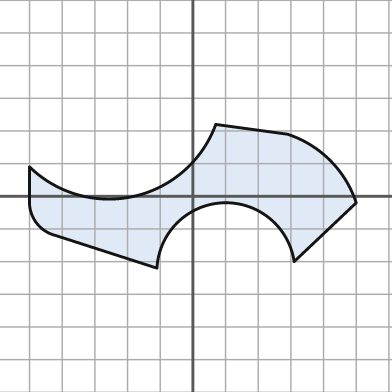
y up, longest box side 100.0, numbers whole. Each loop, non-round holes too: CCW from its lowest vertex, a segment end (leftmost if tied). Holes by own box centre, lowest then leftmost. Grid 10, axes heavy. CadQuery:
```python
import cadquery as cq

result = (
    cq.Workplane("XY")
    .moveTo(-11.0, -22.0)
    .threePointArc((9.0, -2.0), (31.0, -20.0))
    .lineTo(50.0, -2.0)
    .threePointArc((42.0, 11.0), (29.0, 19.0))
    .lineTo(7.0, 22.0)
    .threePointArc((-18.0, 0.0), (-50.0, 9.0))
    .lineTo(-50.0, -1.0)
    .threePointArc((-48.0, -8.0), (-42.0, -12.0))
    .close()
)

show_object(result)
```